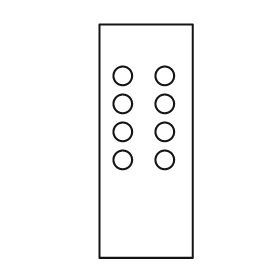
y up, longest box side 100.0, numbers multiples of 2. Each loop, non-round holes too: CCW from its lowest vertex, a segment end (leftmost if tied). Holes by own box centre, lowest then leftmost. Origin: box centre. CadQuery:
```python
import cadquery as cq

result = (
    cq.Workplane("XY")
    .moveTo(-20.0, -50.0)
    .lineTo(20.0, -50.0)
    .lineTo(20.0, 50.0)
    .lineTo(-20.0, 50.0)
    .close()
    .moveTo(-10.0, -8.0)
    .circle(4.0)
    .moveTo(8.0, -8.0)
    .circle(4.0)
    .moveTo(-10.0, 4.0)
    .circle(4.0)
    .moveTo(8.0, 4.0)
    .circle(4.0)
    .moveTo(-10.0, 16.0)
    .circle(4.0)
    .moveTo(8.0, 16.0)
    .circle(4.0)
    .moveTo(-10.0, 28.0)
    .circle(4.0)
    .moveTo(8.0, 28.0)
    .circle(4.0)
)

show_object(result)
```